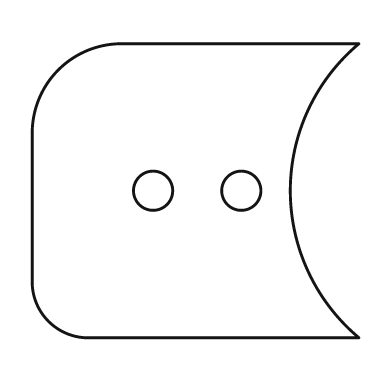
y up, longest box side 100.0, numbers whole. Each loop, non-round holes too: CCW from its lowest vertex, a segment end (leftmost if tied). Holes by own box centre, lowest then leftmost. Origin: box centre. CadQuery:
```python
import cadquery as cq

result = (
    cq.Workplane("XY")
    .moveTo(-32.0, -45.0)
    .lineTo(50.0, -45.0)
    .threePointArc((29.0, 0.0), (50.0, 45.0))
    .lineTo(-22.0, 45.0)
    .threePointArc((-42.0, 37.0), (-50.0, 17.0))
    .lineTo(-50.0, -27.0)
    .threePointArc((-45.0, -40.0), (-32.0, -45.0))
    .close()
    .moveTo(-13.0, 0.0)
    .circle(6.0)
    .moveTo(14.0, 0.0)
    .circle(6.0)
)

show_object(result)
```